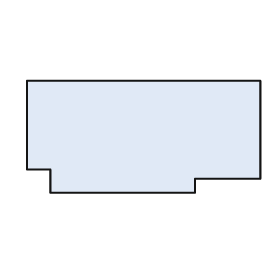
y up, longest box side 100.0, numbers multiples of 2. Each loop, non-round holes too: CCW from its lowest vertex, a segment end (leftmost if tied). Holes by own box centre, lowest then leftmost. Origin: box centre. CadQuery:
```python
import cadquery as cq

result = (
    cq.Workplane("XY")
    .moveTo(-40.0, -24.0)
    .lineTo(22.0, -24.0)
    .lineTo(22.0, -18.0)
    .lineTo(50.0, -18.0)
    .lineTo(50.0, 24.0)
    .lineTo(-50.0, 24.0)
    .lineTo(-50.0, -14.0)
    .lineTo(-40.0, -14.0)
    .close()
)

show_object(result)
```